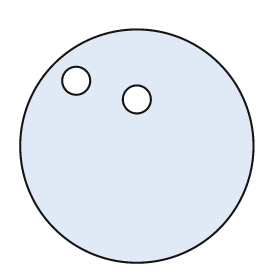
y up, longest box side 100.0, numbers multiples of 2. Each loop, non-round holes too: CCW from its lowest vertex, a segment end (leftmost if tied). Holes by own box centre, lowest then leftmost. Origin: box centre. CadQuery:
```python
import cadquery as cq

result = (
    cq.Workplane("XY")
    .moveTo(0.0, 0.0)
    .circle(50.0)
    .moveTo(0.0, 20.0)
    .circle(6.0)
    .moveTo(-26.0, 28.0)
    .circle(6.0)
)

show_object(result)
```